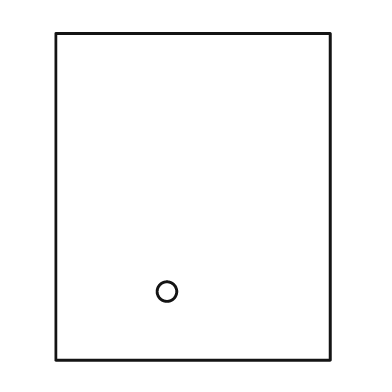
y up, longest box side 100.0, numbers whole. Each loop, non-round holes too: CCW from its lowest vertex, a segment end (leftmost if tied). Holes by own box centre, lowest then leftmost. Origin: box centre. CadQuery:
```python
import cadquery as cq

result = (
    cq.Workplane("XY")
    .moveTo(-42.0, -50.0)
    .lineTo(42.0, -50.0)
    .lineTo(42.0, 50.0)
    .lineTo(-42.0, 50.0)
    .close()
    .moveTo(-8.0, -29.0)
    .circle(3.0)
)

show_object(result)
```